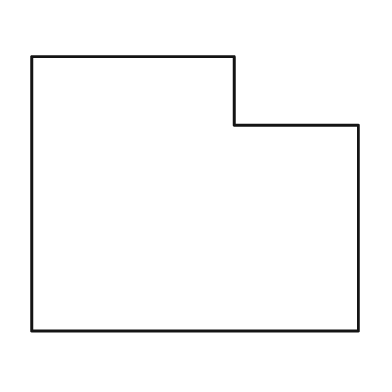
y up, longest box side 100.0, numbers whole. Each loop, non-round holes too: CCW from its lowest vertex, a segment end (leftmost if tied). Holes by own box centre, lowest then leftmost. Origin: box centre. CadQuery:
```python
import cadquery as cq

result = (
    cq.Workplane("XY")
    .moveTo(-50.0, -42.0)
    .lineTo(50.0, -42.0)
    .lineTo(50.0, 21.0)
    .lineTo(12.0, 21.0)
    .lineTo(12.0, 42.0)
    .lineTo(-50.0, 42.0)
    .close()
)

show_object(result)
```